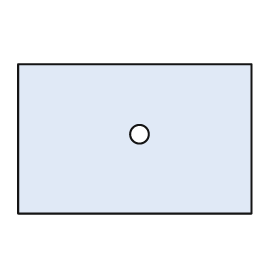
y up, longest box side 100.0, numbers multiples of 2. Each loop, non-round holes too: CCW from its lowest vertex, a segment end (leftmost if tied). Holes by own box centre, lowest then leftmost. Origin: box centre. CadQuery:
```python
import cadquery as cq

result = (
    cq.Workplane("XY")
    .moveTo(-50.0, -32.0)
    .lineTo(50.0, -32.0)
    .lineTo(50.0, 32.0)
    .lineTo(-50.0, 32.0)
    .close()
    .moveTo(2.0, 2.0)
    .circle(4.0)
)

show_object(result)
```